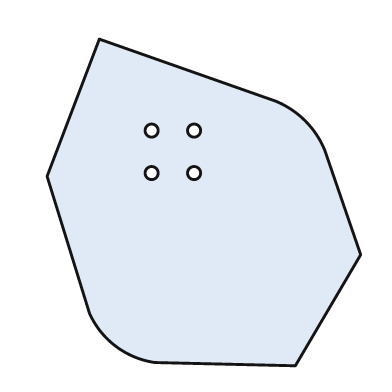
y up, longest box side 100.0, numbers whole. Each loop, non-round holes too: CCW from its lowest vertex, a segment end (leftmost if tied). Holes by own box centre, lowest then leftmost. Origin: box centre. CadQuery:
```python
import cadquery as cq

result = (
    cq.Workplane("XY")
    .moveTo(28.0, -50.0)
    .lineTo(48.0, -16.0)
    .lineTo(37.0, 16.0)
    .threePointArc((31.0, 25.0), (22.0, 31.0))
    .lineTo(-32.0, 50.0)
    .lineTo(-48.0, 8.0)
    .lineTo(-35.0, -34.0)
    .threePointArc((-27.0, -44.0), (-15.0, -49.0))
    .close()
    .moveTo(-16.0, 9.0)
    .circle(2.0)
    .moveTo(-3.0, 9.0)
    .circle(2.0)
    .moveTo(-16.0, 22.0)
    .circle(2.0)
    .moveTo(-3.0, 22.0)
    .circle(2.0)
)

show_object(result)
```